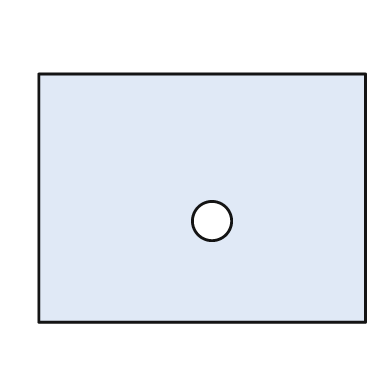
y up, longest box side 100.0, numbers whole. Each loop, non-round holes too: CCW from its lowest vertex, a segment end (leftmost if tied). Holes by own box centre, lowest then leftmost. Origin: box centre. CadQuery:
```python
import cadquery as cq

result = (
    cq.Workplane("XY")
    .moveTo(-50.0, -38.0)
    .lineTo(50.0, -38.0)
    .lineTo(50.0, 38.0)
    .lineTo(-50.0, 38.0)
    .close()
    .moveTo(3.0, -7.0)
    .circle(6.0)
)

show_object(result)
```